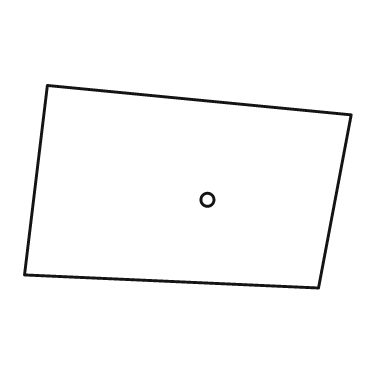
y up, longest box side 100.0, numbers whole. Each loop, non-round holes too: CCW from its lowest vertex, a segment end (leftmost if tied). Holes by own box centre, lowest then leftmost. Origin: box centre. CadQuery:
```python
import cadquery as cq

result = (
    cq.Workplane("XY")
    .moveTo(40.0, -31.0)
    .lineTo(50.0, 22.0)
    .lineTo(-43.0, 31.0)
    .lineTo(-50.0, -27.0)
    .close()
    .moveTo(6.0, -4.0)
    .circle(2.0)
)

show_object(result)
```